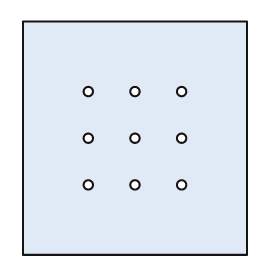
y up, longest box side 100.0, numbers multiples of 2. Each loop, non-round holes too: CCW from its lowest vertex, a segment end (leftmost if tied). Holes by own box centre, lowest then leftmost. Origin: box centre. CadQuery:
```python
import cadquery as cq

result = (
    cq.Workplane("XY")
    .moveTo(-48.0, -50.0)
    .lineTo(48.0, -50.0)
    .lineTo(48.0, 50.0)
    .lineTo(-48.0, 50.0)
    .close()
    .moveTo(-20.0, -20.0)
    .circle(2.0)
    .moveTo(0.0, -20.0)
    .circle(2.0)
    .moveTo(20.0, -20.0)
    .circle(2.0)
    .moveTo(-20.0, 0.0)
    .circle(2.0)
    .moveTo(0.0, 0.0)
    .circle(2.0)
    .moveTo(20.0, 0.0)
    .circle(2.0)
    .moveTo(-20.0, 20.0)
    .circle(2.0)
    .moveTo(0.0, 20.0)
    .circle(2.0)
    .moveTo(20.0, 20.0)
    .circle(2.0)
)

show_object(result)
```